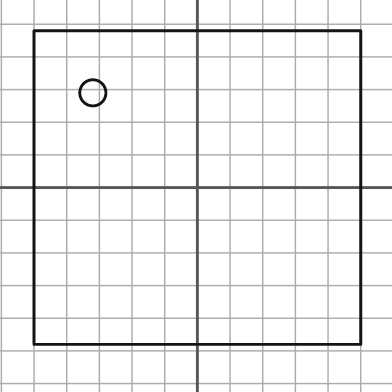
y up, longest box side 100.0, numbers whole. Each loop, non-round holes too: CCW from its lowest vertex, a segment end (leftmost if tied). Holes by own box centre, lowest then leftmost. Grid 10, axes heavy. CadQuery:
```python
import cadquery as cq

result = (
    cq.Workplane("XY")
    .moveTo(-50.0, -48.0)
    .lineTo(50.0, -48.0)
    .lineTo(50.0, 48.0)
    .lineTo(-50.0, 48.0)
    .close()
    .moveTo(-32.0, 29.0)
    .circle(4.0)
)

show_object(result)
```